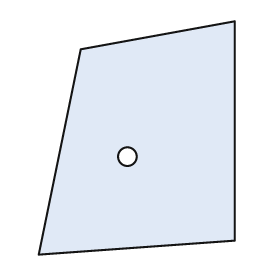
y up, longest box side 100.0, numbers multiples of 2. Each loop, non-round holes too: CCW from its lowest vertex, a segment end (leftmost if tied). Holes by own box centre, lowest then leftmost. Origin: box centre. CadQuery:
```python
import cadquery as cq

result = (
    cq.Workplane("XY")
    .moveTo(-42.0, -50.0)
    .lineTo(42.0, -44.0)
    .lineTo(42.0, 50.0)
    .lineTo(-24.0, 38.0)
    .close()
    .moveTo(-4.0, -8.0)
    .circle(4.0)
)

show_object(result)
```